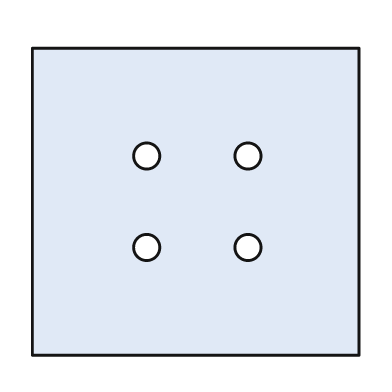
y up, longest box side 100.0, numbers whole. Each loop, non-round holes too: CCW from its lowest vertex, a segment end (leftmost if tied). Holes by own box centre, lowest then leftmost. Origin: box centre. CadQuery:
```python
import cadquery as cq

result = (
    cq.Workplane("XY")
    .moveTo(-50.0, -47.0)
    .lineTo(50.0, -47.0)
    .lineTo(50.0, 47.0)
    .lineTo(-50.0, 47.0)
    .close()
    .moveTo(-15.0, -14.0)
    .circle(4.0)
    .moveTo(16.0, -14.0)
    .circle(4.0)
    .moveTo(-15.0, 14.0)
    .circle(4.0)
    .moveTo(16.0, 14.0)
    .circle(4.0)
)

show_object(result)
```